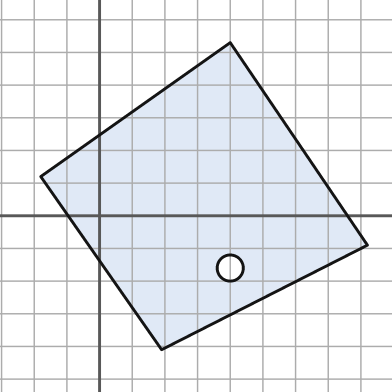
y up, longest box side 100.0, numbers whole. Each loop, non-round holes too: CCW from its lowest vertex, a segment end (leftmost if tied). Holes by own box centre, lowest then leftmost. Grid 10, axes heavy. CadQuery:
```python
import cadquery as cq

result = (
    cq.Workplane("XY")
    .moveTo(19.0, -41.0)
    .lineTo(82.0, -9.0)
    .lineTo(40.0, 53.0)
    .lineTo(-18.0, 12.0)
    .close()
    .moveTo(40.0, -16.0)
    .circle(4.0)
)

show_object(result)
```